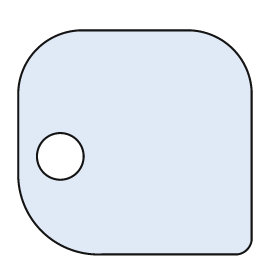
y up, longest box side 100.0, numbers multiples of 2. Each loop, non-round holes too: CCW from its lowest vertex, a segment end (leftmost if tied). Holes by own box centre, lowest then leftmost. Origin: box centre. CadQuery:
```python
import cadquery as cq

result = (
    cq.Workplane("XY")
    .moveTo(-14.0, -48.0)
    .lineTo(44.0, -48.0)
    .threePointArc((48.0, -46.0), (50.0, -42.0))
    .lineTo(50.0, 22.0)
    .threePointArc((42.0, 40.0), (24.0, 48.0))
    .lineTo(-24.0, 48.0)
    .threePointArc((-42.0, 40.0), (-50.0, 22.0))
    .lineTo(-50.0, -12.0)
    .threePointArc((-40.0, -38.0), (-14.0, -48.0))
    .close()
    .moveTo(-32.0, -6.0)
    .circle(10.0)
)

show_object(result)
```